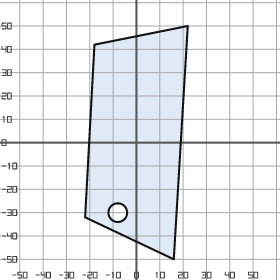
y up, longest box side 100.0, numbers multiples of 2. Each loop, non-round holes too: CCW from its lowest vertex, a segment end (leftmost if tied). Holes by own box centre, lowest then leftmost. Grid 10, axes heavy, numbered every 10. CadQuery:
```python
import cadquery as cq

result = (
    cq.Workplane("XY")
    .moveTo(16.0, -50.0)
    .lineTo(22.0, 50.0)
    .lineTo(-18.0, 42.0)
    .lineTo(-22.0, -32.0)
    .close()
    .moveTo(-8.0, -30.0)
    .circle(4.0)
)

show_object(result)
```